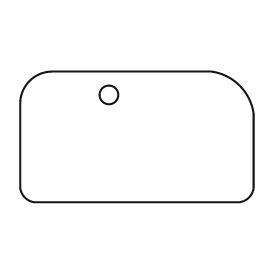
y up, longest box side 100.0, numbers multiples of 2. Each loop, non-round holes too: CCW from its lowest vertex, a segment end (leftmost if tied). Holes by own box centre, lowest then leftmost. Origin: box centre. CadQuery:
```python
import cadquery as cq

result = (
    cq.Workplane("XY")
    .moveTo(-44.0, -28.0)
    .lineTo(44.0, -28.0)
    .threePointArc((48.0, -26.0), (50.0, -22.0))
    .lineTo(50.0, 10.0)
    .threePointArc((44.0, 22.0), (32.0, 28.0))
    .lineTo(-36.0, 28.0)
    .threePointArc((-46.0, 24.0), (-50.0, 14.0))
    .lineTo(-50.0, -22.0)
    .threePointArc((-48.0, -26.0), (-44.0, -28.0))
    .close()
    .moveTo(-12.0, 18.0)
    .circle(4.0)
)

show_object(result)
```